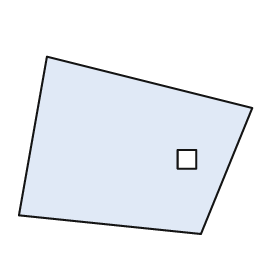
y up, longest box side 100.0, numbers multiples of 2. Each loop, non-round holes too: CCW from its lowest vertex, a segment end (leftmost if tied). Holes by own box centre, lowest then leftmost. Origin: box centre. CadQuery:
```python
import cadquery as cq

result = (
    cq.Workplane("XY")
    .moveTo(28.0, -38.0)
    .lineTo(50.0, 16.0)
    .lineTo(-38.0, 38.0)
    .lineTo(-50.0, -30.0)
    .close()
    .moveTo(18.0, -10.0)
    .lineTo(26.0, -10.0)
    .lineTo(26.0, -2.0)
    .lineTo(18.0, -2.0)
    .close()
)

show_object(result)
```